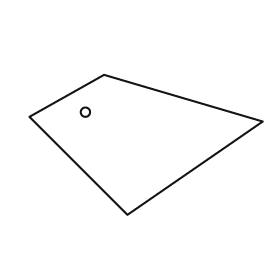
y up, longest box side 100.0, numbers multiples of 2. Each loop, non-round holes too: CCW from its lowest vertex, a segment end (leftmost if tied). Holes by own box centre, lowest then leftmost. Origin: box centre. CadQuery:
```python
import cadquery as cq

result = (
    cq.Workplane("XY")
    .moveTo(-8.0, -30.0)
    .lineTo(50.0, 10.0)
    .lineTo(-18.0, 30.0)
    .lineTo(-50.0, 12.0)
    .close()
    .moveTo(-26.0, 14.0)
    .circle(2.0)
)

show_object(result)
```